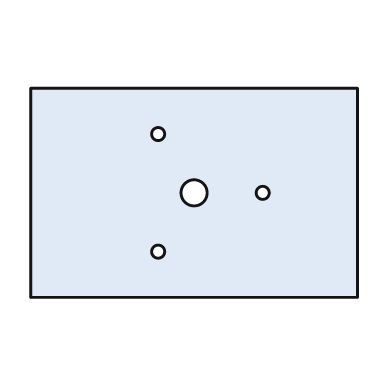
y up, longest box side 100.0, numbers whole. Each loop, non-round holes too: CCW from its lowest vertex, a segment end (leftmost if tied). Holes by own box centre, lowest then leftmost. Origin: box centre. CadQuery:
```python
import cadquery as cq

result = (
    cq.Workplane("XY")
    .moveTo(-50.0, -32.0)
    .lineTo(50.0, -32.0)
    .lineTo(50.0, 32.0)
    .lineTo(-50.0, 32.0)
    .close()
    .moveTo(-11.0, -18.0)
    .circle(2.0)
    .moveTo(0.0, 0.0)
    .circle(4.0)
    .moveTo(21.0, 0.0)
    .circle(2.0)
    .moveTo(-11.0, 18.0)
    .circle(2.0)
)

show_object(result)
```